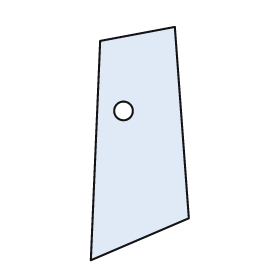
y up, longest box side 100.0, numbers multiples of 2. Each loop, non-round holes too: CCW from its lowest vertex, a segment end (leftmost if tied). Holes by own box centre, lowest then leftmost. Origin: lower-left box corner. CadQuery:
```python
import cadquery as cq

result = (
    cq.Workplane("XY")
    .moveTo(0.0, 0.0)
    .lineTo(42.0, 18.0)
    .lineTo(36.0, 100.0)
    .lineTo(4.0, 94.0)
    .close()
    .moveTo(14.0, 64.0)
    .circle(4.0)
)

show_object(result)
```